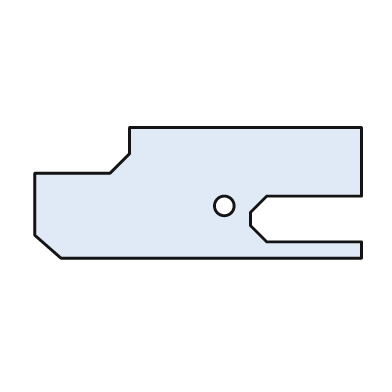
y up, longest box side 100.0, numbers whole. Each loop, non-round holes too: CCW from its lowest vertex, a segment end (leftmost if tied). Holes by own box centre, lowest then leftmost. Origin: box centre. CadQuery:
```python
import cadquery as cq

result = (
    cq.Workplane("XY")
    .moveTo(-42.0, -20.0)
    .lineTo(50.0, -20.0)
    .lineTo(50.0, -15.0)
    .lineTo(21.0, -15.0)
    .lineTo(16.0, -10.0)
    .lineTo(16.0, -6.0)
    .lineTo(21.0, -1.0)
    .lineTo(50.0, -1.0)
    .lineTo(50.0, 20.0)
    .lineTo(-21.0, 20.0)
    .lineTo(-21.0, 12.0)
    .lineTo(-27.0, 6.0)
    .lineTo(-50.0, 6.0)
    .lineTo(-50.0, -13.0)
    .close()
    .moveTo(8.0, -4.0)
    .circle(3.0)
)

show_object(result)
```